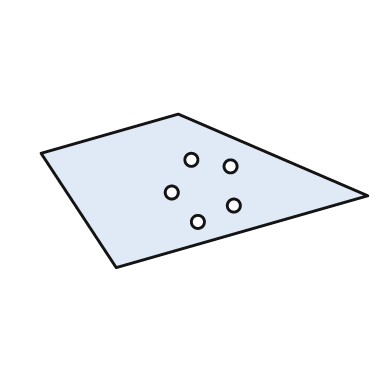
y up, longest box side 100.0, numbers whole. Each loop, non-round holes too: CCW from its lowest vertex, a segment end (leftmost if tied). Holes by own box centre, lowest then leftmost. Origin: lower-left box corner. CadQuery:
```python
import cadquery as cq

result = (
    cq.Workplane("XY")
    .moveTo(23.0, 0.0)
    .lineTo(100.0, 22.0)
    .lineTo(42.0, 47.0)
    .lineTo(0.0, 35.0)
    .close()
    .moveTo(48.0, 14.0)
    .circle(2.0)
    .moveTo(59.0, 19.0)
    .circle(2.0)
    .moveTo(40.0, 23.0)
    .circle(2.0)
    .moveTo(58.0, 31.0)
    .circle(2.0)
    .moveTo(46.0, 33.0)
    .circle(2.0)
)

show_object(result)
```